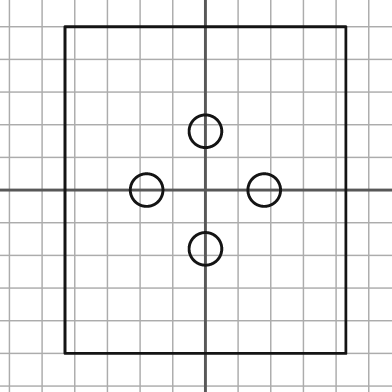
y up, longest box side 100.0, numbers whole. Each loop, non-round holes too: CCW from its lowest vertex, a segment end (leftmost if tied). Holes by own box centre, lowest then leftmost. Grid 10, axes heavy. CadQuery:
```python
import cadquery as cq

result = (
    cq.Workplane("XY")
    .moveTo(-43.0, -50.0)
    .lineTo(43.0, -50.0)
    .lineTo(43.0, 50.0)
    .lineTo(-43.0, 50.0)
    .close()
    .moveTo(0.0, -18.0)
    .circle(5.0)
    .moveTo(-18.0, 0.0)
    .circle(5.0)
    .moveTo(18.0, 0.0)
    .circle(5.0)
    .moveTo(0.0, 18.0)
    .circle(5.0)
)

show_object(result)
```